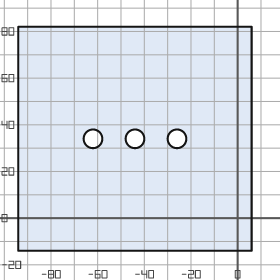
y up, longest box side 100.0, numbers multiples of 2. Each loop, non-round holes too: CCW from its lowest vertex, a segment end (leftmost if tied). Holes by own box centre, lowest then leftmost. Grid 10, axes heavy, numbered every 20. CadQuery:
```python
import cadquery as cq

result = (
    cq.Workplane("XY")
    .moveTo(-94.0, -14.0)
    .lineTo(6.0, -14.0)
    .lineTo(6.0, 82.0)
    .lineTo(-94.0, 82.0)
    .close()
    .moveTo(-62.0, 34.0)
    .circle(4.0)
    .moveTo(-44.0, 34.0)
    .circle(4.0)
    .moveTo(-26.0, 34.0)
    .circle(4.0)
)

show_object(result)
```